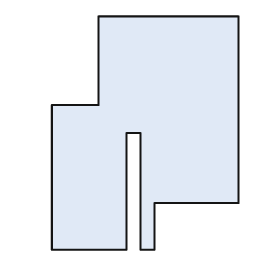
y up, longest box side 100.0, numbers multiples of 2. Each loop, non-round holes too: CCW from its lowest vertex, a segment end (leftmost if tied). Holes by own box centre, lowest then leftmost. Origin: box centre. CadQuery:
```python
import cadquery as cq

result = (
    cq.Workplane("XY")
    .moveTo(-40.0, -50.0)
    .lineTo(-8.0, -50.0)
    .lineTo(-8.0, 0.0)
    .lineTo(-2.0, 0.0)
    .lineTo(-2.0, -50.0)
    .lineTo(4.0, -50.0)
    .lineTo(4.0, -30.0)
    .lineTo(40.0, -30.0)
    .lineTo(40.0, 50.0)
    .lineTo(-20.0, 50.0)
    .lineTo(-20.0, 12.0)
    .lineTo(-40.0, 12.0)
    .close()
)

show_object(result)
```